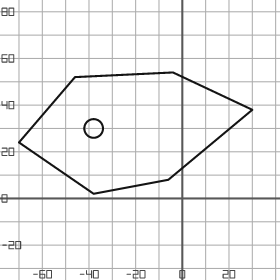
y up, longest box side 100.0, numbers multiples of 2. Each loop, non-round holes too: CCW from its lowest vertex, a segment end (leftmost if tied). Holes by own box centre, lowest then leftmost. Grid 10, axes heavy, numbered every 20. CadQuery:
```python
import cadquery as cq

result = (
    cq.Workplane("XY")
    .moveTo(-38.0, 2.0)
    .lineTo(-6.0, 8.0)
    .lineTo(30.0, 38.0)
    .lineTo(-4.0, 54.0)
    .lineTo(-46.0, 52.0)
    .lineTo(-70.0, 24.0)
    .close()
    .moveTo(-38.0, 30.0)
    .circle(4.0)
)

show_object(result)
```